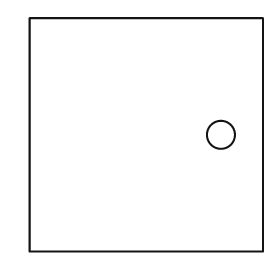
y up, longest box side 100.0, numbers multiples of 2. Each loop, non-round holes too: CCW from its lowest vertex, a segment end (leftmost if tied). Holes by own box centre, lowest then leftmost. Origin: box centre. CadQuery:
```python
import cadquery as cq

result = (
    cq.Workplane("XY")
    .moveTo(-50.0, -50.0)
    .lineTo(50.0, -50.0)
    .lineTo(50.0, 50.0)
    .lineTo(-50.0, 50.0)
    .close()
    .moveTo(32.0, 0.0)
    .circle(6.0)
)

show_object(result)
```